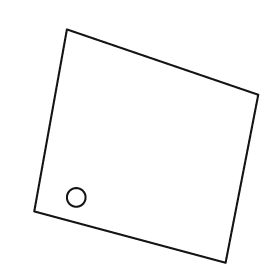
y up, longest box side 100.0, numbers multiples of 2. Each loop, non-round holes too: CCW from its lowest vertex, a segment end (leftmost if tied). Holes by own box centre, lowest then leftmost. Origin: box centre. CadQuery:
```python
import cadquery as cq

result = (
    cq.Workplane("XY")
    .moveTo(34.0, -50.0)
    .lineTo(48.0, 22.0)
    .lineTo(-34.0, 50.0)
    .lineTo(-48.0, -28.0)
    .close()
    .moveTo(-30.0, -22.0)
    .circle(4.0)
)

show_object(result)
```